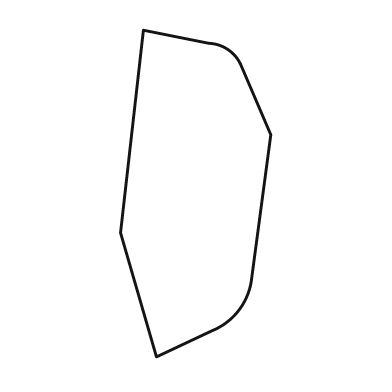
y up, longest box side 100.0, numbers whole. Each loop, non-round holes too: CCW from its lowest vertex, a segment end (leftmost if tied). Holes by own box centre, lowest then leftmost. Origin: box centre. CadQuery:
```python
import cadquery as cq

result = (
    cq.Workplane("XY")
    .moveTo(-12.0, -50.0)
    .lineTo(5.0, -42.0)
    .threePointArc((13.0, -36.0), (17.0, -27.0))
    .lineTo(23.0, 18.0)
    .lineTo(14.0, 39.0)
    .threePointArc((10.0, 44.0), (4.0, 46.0))
    .lineTo(-16.0, 50.0)
    .lineTo(-23.0, -12.0)
    .close()
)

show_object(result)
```